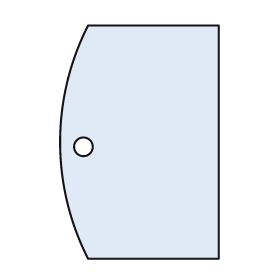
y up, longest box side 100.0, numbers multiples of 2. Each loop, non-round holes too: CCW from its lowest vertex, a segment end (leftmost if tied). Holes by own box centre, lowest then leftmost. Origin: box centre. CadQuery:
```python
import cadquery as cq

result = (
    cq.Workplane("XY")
    .moveTo(-22.0, -50.0)
    .lineTo(34.0, -50.0)
    .lineTo(34.0, 50.0)
    .lineTo(-22.0, 50.0)
    .threePointArc((-34.0, 0.0), (-22.0, -50.0))
    .close()
    .moveTo(-24.0, -2.0)
    .circle(4.0)
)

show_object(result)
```